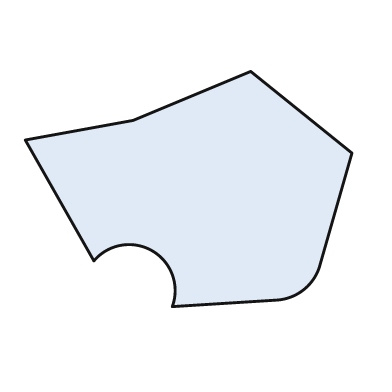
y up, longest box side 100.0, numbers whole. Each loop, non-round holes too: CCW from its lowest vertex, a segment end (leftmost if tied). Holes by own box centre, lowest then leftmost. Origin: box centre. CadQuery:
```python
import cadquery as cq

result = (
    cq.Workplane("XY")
    .moveTo(-5.0, -36.0)
    .lineTo(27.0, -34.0)
    .threePointArc((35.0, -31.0), (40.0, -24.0))
    .lineTo(50.0, 11.0)
    .lineTo(19.0, 36.0)
    .lineTo(-17.0, 21.0)
    .lineTo(-50.0, 15.0)
    .lineTo(-29.0, -22.0)
    .threePointArc((-11.0, -19.0), (-5.0, -36.0))
    .close()
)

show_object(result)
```